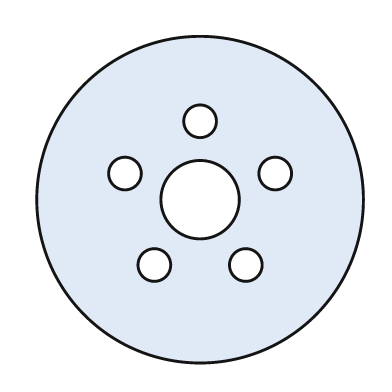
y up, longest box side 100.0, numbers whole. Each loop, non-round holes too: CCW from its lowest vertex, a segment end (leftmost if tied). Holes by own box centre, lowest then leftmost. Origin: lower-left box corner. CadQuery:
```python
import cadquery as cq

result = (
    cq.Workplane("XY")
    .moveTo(50.0, 50.0)
    .circle(50.0)
    .moveTo(36.0, 30.0)
    .circle(5.0)
    .moveTo(64.0, 30.0)
    .circle(5.0)
    .moveTo(50.0, 50.0)
    .circle(12.0)
    .moveTo(27.0, 58.0)
    .circle(5.0)
    .moveTo(73.0, 58.0)
    .circle(5.0)
    .moveTo(50.0, 74.0)
    .circle(5.0)
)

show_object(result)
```